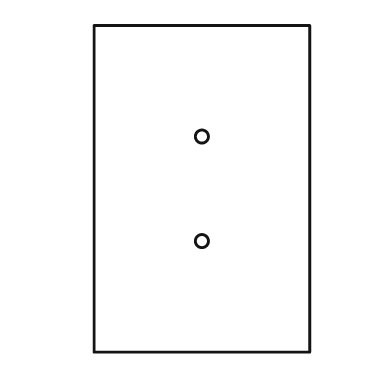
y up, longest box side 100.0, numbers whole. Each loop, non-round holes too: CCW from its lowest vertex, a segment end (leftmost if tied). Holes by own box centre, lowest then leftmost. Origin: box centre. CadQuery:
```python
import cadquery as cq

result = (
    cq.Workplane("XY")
    .moveTo(-33.0, -50.0)
    .lineTo(33.0, -50.0)
    .lineTo(33.0, 50.0)
    .lineTo(-33.0, 50.0)
    .close()
    .moveTo(0.0, -16.0)
    .circle(2.0)
    .moveTo(0.0, 16.0)
    .circle(2.0)
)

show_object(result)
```